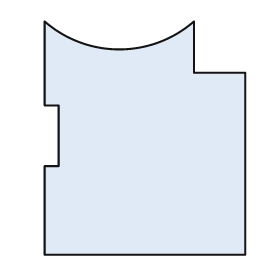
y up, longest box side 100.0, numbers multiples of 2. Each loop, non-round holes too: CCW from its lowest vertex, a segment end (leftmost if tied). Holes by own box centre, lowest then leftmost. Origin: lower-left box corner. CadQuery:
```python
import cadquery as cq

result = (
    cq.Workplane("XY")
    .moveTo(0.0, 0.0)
    .lineTo(86.0, 0.0)
    .lineTo(86.0, 78.0)
    .lineTo(64.0, 78.0)
    .lineTo(64.0, 100.0)
    .threePointArc((32.0, 88.0), (0.0, 100.0))
    .lineTo(0.0, 64.0)
    .lineTo(6.0, 64.0)
    .lineTo(6.0, 38.0)
    .lineTo(0.0, 38.0)
    .close()
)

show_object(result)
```